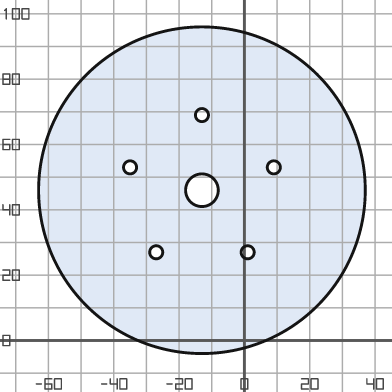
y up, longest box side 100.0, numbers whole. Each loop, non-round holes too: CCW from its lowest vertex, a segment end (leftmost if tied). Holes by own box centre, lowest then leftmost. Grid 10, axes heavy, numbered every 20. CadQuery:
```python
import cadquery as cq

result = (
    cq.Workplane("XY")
    .moveTo(-13.0, 46.0)
    .circle(50.0)
    .moveTo(-27.0, 27.0)
    .circle(2.0)
    .moveTo(1.0, 27.0)
    .circle(2.0)
    .moveTo(-13.0, 46.0)
    .circle(5.0)
    .moveTo(-35.0, 53.0)
    .circle(2.0)
    .moveTo(9.0, 53.0)
    .circle(2.0)
    .moveTo(-13.0, 69.0)
    .circle(2.0)
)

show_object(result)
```